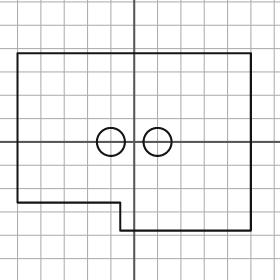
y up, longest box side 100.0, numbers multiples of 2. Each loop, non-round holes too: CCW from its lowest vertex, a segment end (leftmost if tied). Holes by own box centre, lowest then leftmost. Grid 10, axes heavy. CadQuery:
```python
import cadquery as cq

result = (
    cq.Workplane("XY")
    .moveTo(-6.0, -38.0)
    .lineTo(50.0, -38.0)
    .lineTo(50.0, 38.0)
    .lineTo(-50.0, 38.0)
    .lineTo(-50.0, -26.0)
    .lineTo(-6.0, -26.0)
    .close()
    .moveTo(-10.0, 0.0)
    .circle(6.0)
    .moveTo(10.0, 0.0)
    .circle(6.0)
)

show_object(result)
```